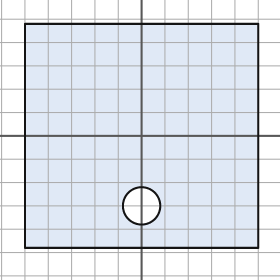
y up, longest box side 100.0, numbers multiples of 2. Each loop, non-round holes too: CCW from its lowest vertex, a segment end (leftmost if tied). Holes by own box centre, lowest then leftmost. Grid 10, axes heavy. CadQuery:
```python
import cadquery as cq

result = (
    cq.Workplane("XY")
    .moveTo(-50.0, -48.0)
    .lineTo(50.0, -48.0)
    .lineTo(50.0, 48.0)
    .lineTo(-50.0, 48.0)
    .close()
    .moveTo(0.0, -30.0)
    .circle(8.0)
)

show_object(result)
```